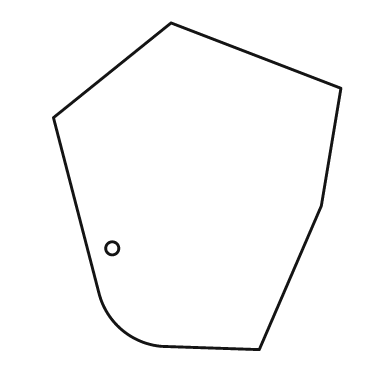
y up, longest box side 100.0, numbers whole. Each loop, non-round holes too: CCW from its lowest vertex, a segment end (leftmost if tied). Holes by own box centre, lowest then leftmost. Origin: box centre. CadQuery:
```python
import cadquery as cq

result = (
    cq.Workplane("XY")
    .moveTo(19.0, -50.0)
    .lineTo(38.0, -6.0)
    .lineTo(44.0, 30.0)
    .lineTo(-8.0, 50.0)
    .lineTo(-44.0, 21.0)
    .lineTo(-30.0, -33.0)
    .threePointArc((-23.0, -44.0), (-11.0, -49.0))
    .close()
    .moveTo(-26.0, -19.0)
    .circle(2.0)
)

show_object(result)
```